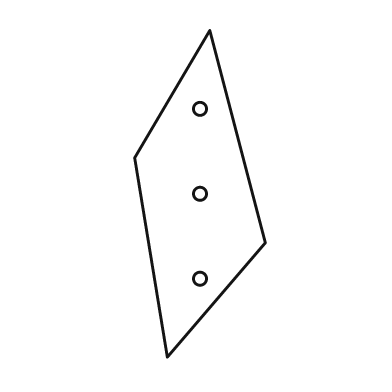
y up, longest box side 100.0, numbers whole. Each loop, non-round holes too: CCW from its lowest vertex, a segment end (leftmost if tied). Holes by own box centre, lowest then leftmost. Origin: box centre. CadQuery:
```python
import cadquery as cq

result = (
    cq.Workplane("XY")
    .moveTo(-10.0, -50.0)
    .lineTo(20.0, -15.0)
    .lineTo(3.0, 50.0)
    .lineTo(-20.0, 11.0)
    .close()
    .moveTo(0.0, -26.0)
    .circle(2.0)
    .moveTo(0.0, 0.0)
    .circle(2.0)
    .moveTo(0.0, 26.0)
    .circle(2.0)
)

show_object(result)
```